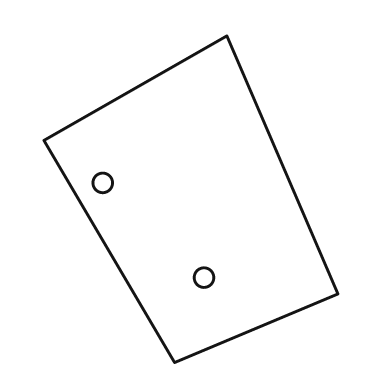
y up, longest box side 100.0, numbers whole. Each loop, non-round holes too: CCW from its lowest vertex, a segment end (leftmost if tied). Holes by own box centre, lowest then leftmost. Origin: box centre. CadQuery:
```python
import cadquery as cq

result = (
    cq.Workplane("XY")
    .moveTo(-5.0, -50.0)
    .lineTo(45.0, -29.0)
    .lineTo(11.0, 50.0)
    .lineTo(-45.0, 18.0)
    .close()
    .moveTo(4.0, -24.0)
    .circle(3.0)
    .moveTo(-27.0, 5.0)
    .circle(3.0)
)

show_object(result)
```